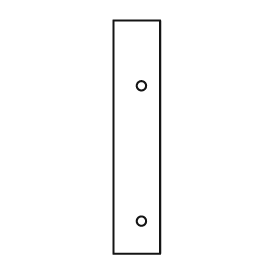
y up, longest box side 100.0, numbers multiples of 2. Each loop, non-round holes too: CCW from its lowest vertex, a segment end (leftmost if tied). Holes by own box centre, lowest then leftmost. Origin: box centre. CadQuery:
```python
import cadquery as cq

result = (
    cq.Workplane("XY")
    .moveTo(-10.0, -50.0)
    .lineTo(10.0, -50.0)
    .lineTo(10.0, 50.0)
    .lineTo(-10.0, 50.0)
    .close()
    .moveTo(2.0, -36.0)
    .circle(2.0)
    .moveTo(2.0, 22.0)
    .circle(2.0)
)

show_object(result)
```